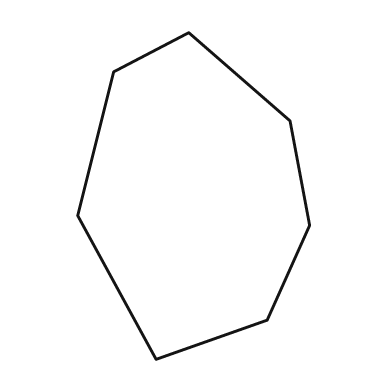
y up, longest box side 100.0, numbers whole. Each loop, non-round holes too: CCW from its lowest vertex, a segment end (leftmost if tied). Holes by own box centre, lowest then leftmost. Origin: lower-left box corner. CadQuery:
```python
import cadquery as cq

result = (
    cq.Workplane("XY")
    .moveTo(24.0, 0.0)
    .lineTo(58.0, 12.0)
    .lineTo(71.0, 41.0)
    .lineTo(65.0, 73.0)
    .lineTo(34.0, 100.0)
    .lineTo(11.0, 88.0)
    .lineTo(0.0, 44.0)
    .close()
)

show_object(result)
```